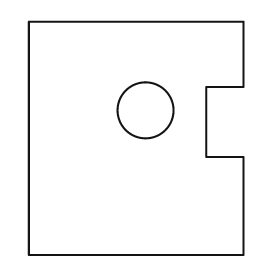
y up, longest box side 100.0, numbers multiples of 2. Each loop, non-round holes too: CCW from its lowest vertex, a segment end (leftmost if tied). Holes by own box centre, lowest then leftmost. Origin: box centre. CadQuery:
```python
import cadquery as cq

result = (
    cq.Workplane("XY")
    .moveTo(-46.0, -50.0)
    .lineTo(46.0, -50.0)
    .lineTo(46.0, -8.0)
    .lineTo(30.0, -8.0)
    .lineTo(30.0, 22.0)
    .lineTo(46.0, 22.0)
    .lineTo(46.0, 50.0)
    .lineTo(-46.0, 50.0)
    .close()
    .moveTo(4.0, 12.0)
    .circle(12.0)
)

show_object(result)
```